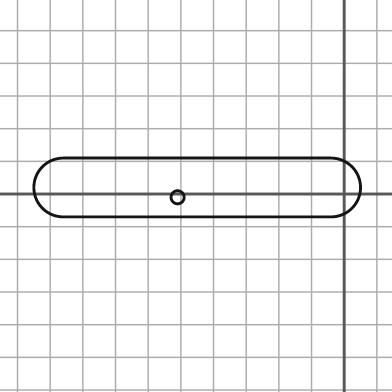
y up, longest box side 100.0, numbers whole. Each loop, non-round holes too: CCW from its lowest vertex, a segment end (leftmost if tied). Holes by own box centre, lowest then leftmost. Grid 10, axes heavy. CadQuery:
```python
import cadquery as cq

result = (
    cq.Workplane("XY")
    .moveTo(-86.0, -7.0)
    .lineTo(-4.0, -7.0)
    .threePointArc((5.0, 2.0), (-4.0, 11.0))
    .lineTo(-86.0, 11.0)
    .threePointArc((-95.0, 2.0), (-86.0, -7.0))
    .close()
    .moveTo(-51.0, -1.0)
    .circle(2.0)
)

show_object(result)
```